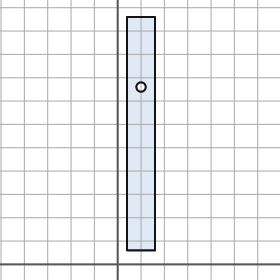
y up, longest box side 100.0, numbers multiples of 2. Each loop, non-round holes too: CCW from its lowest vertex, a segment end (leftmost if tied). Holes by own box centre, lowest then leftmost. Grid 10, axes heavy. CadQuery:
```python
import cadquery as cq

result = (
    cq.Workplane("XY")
    .moveTo(4.0, 6.0)
    .lineTo(16.0, 6.0)
    .lineTo(16.0, 106.0)
    .lineTo(4.0, 106.0)
    .close()
    .moveTo(10.0, 76.0)
    .circle(2.0)
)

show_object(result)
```